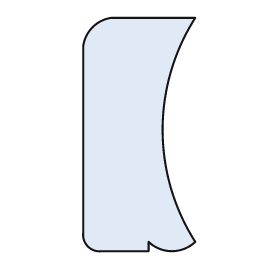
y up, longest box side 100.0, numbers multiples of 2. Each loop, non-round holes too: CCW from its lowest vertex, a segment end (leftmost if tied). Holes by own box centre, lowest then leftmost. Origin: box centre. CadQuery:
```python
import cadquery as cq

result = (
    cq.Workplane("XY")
    .moveTo(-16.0, -50.0)
    .lineTo(4.0, -50.0)
    .lineTo(4.0, -46.0)
    .threePointArc((14.0, -50.0), (24.0, -46.0))
    .threePointArc((10.0, 2.0), (24.0, 50.0))
    .lineTo(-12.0, 50.0)
    .threePointArc((-20.0, 46.0), (-24.0, 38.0))
    .lineTo(-24.0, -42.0)
    .threePointArc((-22.0, -48.0), (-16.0, -50.0))
    .close()
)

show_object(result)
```